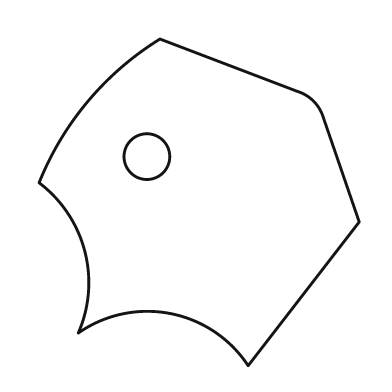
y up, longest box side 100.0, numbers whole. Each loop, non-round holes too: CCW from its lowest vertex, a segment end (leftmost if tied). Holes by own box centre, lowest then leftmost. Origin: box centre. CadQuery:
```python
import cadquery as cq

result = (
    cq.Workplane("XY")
    .moveTo(15.0, -50.0)
    .lineTo(49.0, -6.0)
    .lineTo(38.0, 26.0)
    .threePointArc((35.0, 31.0), (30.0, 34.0))
    .lineTo(-12.0, 50.0)
    .threePointArc((-34.0, 31.0), (-49.0, 6.0))
    .threePointArc((-35.0, -15.0), (-37.0, -40.0))
    .threePointArc((-9.0, -34.0), (15.0, -50.0))
    .close()
    .moveTo(-16.0, 14.0)
    .circle(7.0)
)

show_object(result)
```